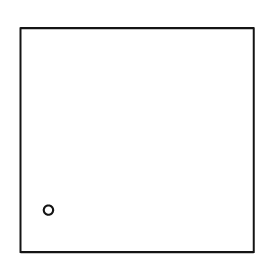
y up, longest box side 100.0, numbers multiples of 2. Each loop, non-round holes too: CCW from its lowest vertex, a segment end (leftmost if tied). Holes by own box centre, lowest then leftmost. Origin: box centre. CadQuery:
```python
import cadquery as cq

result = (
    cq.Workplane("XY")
    .moveTo(-50.0, -48.0)
    .lineTo(50.0, -48.0)
    .lineTo(50.0, 48.0)
    .lineTo(-50.0, 48.0)
    .close()
    .moveTo(-38.0, -30.0)
    .circle(2.0)
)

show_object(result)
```